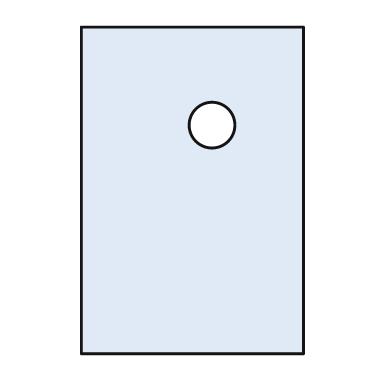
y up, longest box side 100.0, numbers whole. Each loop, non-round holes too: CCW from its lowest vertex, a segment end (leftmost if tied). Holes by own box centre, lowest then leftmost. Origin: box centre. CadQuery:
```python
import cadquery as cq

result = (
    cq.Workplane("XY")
    .moveTo(-34.0, -50.0)
    .lineTo(34.0, -50.0)
    .lineTo(34.0, 50.0)
    .lineTo(-34.0, 50.0)
    .close()
    .moveTo(6.0, 20.0)
    .circle(7.0)
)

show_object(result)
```